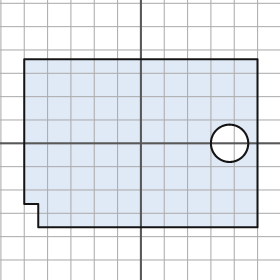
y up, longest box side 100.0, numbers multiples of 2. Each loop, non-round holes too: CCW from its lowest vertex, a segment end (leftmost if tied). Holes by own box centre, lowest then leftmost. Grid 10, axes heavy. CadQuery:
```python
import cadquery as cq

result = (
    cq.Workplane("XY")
    .moveTo(-44.0, -36.0)
    .lineTo(50.0, -36.0)
    .lineTo(50.0, 36.0)
    .lineTo(-50.0, 36.0)
    .lineTo(-50.0, -26.0)
    .lineTo(-44.0, -26.0)
    .close()
    .moveTo(38.0, 0.0)
    .circle(8.0)
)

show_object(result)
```